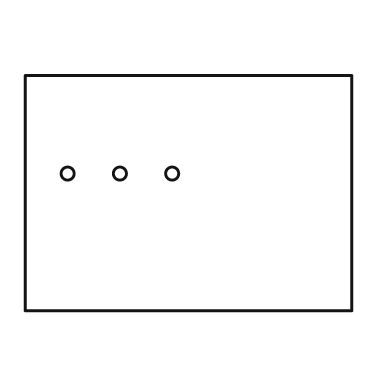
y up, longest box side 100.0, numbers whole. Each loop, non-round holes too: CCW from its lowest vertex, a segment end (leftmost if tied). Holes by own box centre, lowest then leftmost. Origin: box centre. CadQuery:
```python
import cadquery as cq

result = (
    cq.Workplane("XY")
    .moveTo(-50.0, -36.0)
    .lineTo(50.0, -36.0)
    .lineTo(50.0, 36.0)
    .lineTo(-50.0, 36.0)
    .close()
    .moveTo(-37.0, 6.0)
    .circle(2.0)
    .moveTo(-21.0, 6.0)
    .circle(2.0)
    .moveTo(-5.0, 6.0)
    .circle(2.0)
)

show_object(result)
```